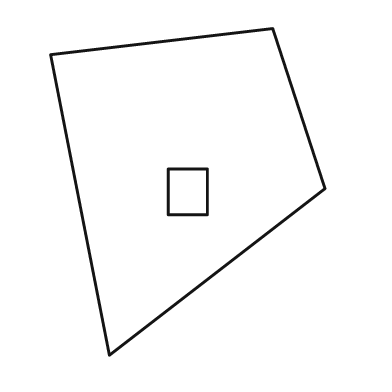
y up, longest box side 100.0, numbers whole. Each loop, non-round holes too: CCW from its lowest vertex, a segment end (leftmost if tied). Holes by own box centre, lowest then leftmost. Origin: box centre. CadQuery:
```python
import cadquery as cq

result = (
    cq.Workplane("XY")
    .moveTo(-24.0, -50.0)
    .lineTo(42.0, 1.0)
    .lineTo(26.0, 50.0)
    .lineTo(-42.0, 42.0)
    .close()
    .moveTo(-6.0, -7.0)
    .lineTo(6.0, -7.0)
    .lineTo(6.0, 7.0)
    .lineTo(-6.0, 7.0)
    .close()
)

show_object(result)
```